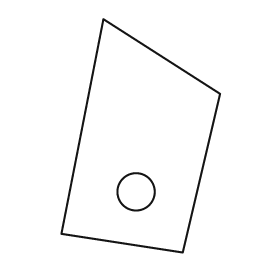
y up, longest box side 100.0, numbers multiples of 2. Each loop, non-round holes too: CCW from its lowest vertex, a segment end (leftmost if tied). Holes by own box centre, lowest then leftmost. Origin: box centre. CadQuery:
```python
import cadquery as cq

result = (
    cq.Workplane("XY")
    .moveTo(18.0, -50.0)
    .lineTo(34.0, 18.0)
    .lineTo(-16.0, 50.0)
    .lineTo(-34.0, -42.0)
    .close()
    .moveTo(-2.0, -24.0)
    .circle(8.0)
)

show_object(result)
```